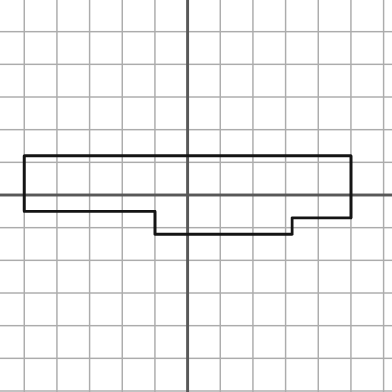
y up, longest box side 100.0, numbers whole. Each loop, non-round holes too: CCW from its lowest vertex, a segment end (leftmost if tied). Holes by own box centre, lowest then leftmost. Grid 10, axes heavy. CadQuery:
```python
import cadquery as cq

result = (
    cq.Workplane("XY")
    .moveTo(-10.0, -12.0)
    .lineTo(32.0, -12.0)
    .lineTo(32.0, -7.0)
    .lineTo(50.0, -7.0)
    .lineTo(50.0, 12.0)
    .lineTo(-50.0, 12.0)
    .lineTo(-50.0, -5.0)
    .lineTo(-10.0, -5.0)
    .close()
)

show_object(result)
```